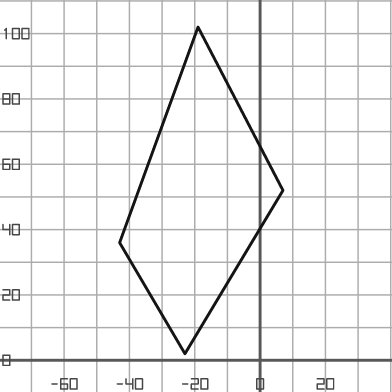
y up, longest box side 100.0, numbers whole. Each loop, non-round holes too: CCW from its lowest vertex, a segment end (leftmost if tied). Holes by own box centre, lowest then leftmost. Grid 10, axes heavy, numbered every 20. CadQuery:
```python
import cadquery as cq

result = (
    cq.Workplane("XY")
    .moveTo(-23.0, 2.0)
    .lineTo(7.0, 52.0)
    .lineTo(-19.0, 102.0)
    .lineTo(-43.0, 36.0)
    .close()
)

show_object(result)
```